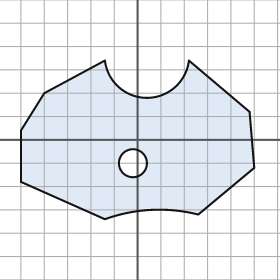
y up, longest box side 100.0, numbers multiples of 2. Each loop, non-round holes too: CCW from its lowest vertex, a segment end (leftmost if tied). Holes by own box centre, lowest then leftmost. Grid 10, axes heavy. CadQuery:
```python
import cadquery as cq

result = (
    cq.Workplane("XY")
    .moveTo(-14.0, -34.0)
    .threePointArc((6.0, -30.0), (26.0, -32.0))
    .lineTo(50.0, -12.0)
    .lineTo(48.0, 12.0)
    .lineTo(22.0, 34.0)
    .threePointArc((4.0, 18.0), (-14.0, 34.0))
    .lineTo(-40.0, 20.0)
    .lineTo(-50.0, 4.0)
    .lineTo(-50.0, -18.0)
    .close()
    .moveTo(-2.0, -10.0)
    .circle(6.0)
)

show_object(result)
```